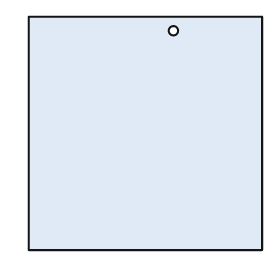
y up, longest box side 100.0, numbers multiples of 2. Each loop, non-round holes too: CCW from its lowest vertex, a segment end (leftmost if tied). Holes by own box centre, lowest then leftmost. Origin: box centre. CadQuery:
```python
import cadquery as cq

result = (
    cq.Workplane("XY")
    .moveTo(-50.0, -50.0)
    .lineTo(50.0, -50.0)
    .lineTo(50.0, 50.0)
    .lineTo(-50.0, 50.0)
    .close()
    .moveTo(12.0, 44.0)
    .circle(2.0)
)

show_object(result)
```